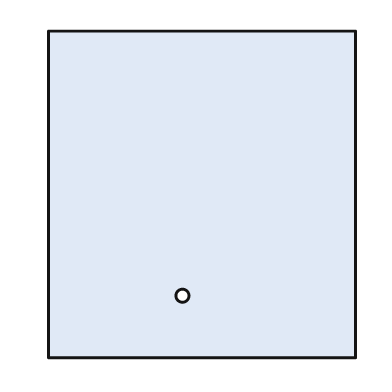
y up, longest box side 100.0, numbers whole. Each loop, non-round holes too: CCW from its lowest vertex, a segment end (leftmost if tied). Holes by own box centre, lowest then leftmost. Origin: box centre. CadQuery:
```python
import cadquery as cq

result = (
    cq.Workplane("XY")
    .moveTo(-47.0, -50.0)
    .lineTo(47.0, -50.0)
    .lineTo(47.0, 50.0)
    .lineTo(-47.0, 50.0)
    .close()
    .moveTo(-6.0, -31.0)
    .circle(2.0)
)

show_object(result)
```